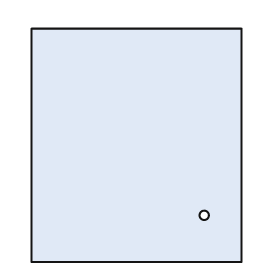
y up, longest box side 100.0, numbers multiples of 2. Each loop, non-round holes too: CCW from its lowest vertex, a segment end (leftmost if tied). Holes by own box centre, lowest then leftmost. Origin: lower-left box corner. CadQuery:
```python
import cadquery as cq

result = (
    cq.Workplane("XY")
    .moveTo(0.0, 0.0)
    .lineTo(90.0, 0.0)
    .lineTo(90.0, 100.0)
    .lineTo(0.0, 100.0)
    .close()
    .moveTo(74.0, 20.0)
    .circle(2.0)
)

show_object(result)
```